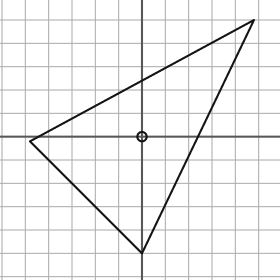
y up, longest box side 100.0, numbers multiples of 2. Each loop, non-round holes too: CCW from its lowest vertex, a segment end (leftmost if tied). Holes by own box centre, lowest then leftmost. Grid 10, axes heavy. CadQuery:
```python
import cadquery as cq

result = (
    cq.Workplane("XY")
    .moveTo(0.0, -50.0)
    .lineTo(48.0, 50.0)
    .lineTo(-48.0, -2.0)
    .close()
    .moveTo(0.0, 0.0)
    .circle(2.0)
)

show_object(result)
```